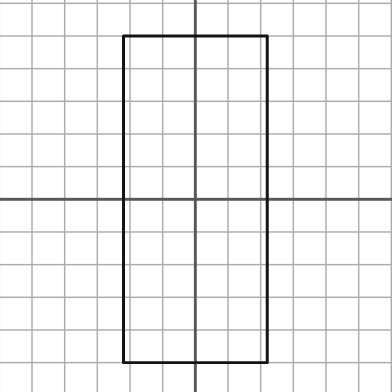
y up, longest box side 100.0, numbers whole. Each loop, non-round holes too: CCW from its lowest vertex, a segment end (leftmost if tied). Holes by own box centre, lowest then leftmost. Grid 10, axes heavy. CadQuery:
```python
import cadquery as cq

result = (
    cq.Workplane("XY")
    .moveTo(-22.0, -50.0)
    .lineTo(22.0, -50.0)
    .lineTo(22.0, 50.0)
    .lineTo(-22.0, 50.0)
    .close()
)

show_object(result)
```